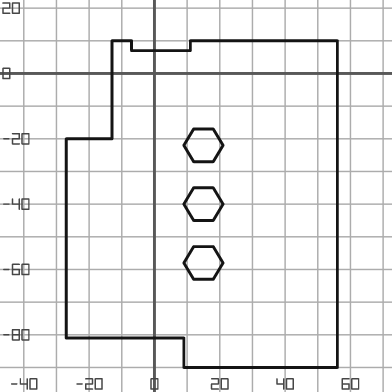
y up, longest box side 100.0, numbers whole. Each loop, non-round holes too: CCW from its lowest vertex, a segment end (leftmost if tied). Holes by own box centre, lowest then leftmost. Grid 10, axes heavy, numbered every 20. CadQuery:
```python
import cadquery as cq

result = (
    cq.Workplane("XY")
    .moveTo(9.0, -90.0)
    .lineTo(56.0, -90.0)
    .lineTo(56.0, 10.0)
    .lineTo(11.0, 10.0)
    .lineTo(11.0, 7.0)
    .lineTo(-7.0, 7.0)
    .lineTo(-7.0, 10.0)
    .lineTo(-13.0, 10.0)
    .lineTo(-13.0, -20.0)
    .lineTo(-27.0, -20.0)
    .lineTo(-27.0, -81.0)
    .lineTo(9.0, -81.0)
    .close()
    .moveTo(12.0, -63.0)
    .lineTo(18.0, -63.0)
    .lineTo(21.0, -58.0)
    .lineTo(18.0, -53.0)
    .lineTo(12.0, -53.0)
    .lineTo(9.0, -58.0)
    .close()
    .moveTo(12.0, -45.0)
    .lineTo(18.0, -45.0)
    .lineTo(21.0, -40.0)
    .lineTo(18.0, -35.0)
    .lineTo(12.0, -35.0)
    .lineTo(9.0, -40.0)
    .close()
    .moveTo(12.0, -27.0)
    .lineTo(18.0, -27.0)
    .lineTo(21.0, -22.0)
    .lineTo(18.0, -17.0)
    .lineTo(12.0, -17.0)
    .lineTo(9.0, -22.0)
    .close()
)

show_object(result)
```